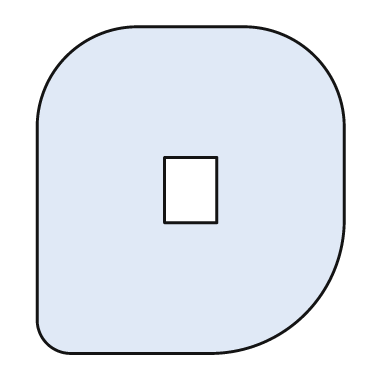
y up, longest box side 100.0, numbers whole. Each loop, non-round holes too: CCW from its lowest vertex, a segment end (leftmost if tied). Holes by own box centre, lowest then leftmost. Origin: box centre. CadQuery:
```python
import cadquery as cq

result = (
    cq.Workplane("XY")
    .moveTo(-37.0, -50.0)
    .lineTo(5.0, -50.0)
    .threePointArc((35.0, -38.0), (47.0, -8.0))
    .lineTo(47.0, 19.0)
    .threePointArc((38.0, 41.0), (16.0, 50.0))
    .lineTo(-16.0, 50.0)
    .threePointArc((-38.0, 41.0), (-47.0, 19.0))
    .lineTo(-47.0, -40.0)
    .threePointArc((-44.0, -47.0), (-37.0, -50.0))
    .close()
    .moveTo(-8.0, -10.0)
    .lineTo(8.0, -10.0)
    .lineTo(8.0, 10.0)
    .lineTo(-8.0, 10.0)
    .close()
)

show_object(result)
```